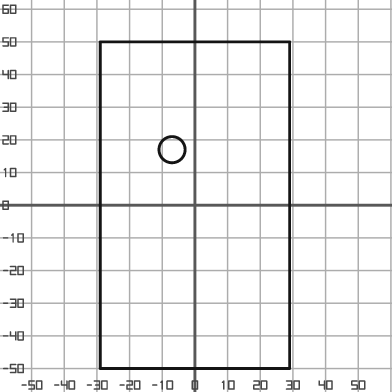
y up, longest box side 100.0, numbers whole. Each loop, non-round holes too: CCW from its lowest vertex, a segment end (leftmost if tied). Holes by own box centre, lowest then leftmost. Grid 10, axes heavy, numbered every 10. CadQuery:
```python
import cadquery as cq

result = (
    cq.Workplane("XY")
    .moveTo(-29.0, -50.0)
    .lineTo(29.0, -50.0)
    .lineTo(29.0, 50.0)
    .lineTo(-29.0, 50.0)
    .close()
    .moveTo(-7.0, 17.0)
    .circle(4.0)
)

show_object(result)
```